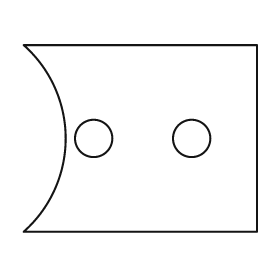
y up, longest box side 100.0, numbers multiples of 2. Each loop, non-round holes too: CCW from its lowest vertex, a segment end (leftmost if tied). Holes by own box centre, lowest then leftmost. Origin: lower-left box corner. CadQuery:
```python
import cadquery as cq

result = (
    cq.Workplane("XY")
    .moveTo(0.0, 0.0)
    .lineTo(100.0, 0.0)
    .lineTo(100.0, 80.0)
    .lineTo(0.0, 80.0)
    .threePointArc((18.0, 40.0), (0.0, 0.0))
    .close()
    .moveTo(30.0, 40.0)
    .circle(8.0)
    .moveTo(72.0, 40.0)
    .circle(8.0)
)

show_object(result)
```